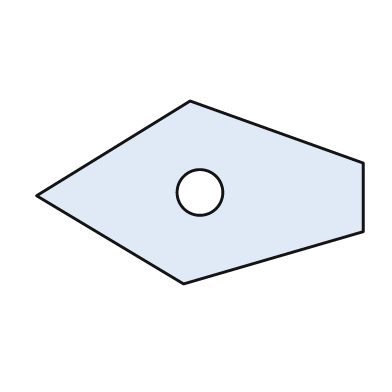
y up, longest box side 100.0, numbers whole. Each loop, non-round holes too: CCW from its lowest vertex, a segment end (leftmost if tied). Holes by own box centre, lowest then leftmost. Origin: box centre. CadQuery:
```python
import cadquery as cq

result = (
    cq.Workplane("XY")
    .moveTo(-5.0, -28.0)
    .lineTo(50.0, -12.0)
    .lineTo(50.0, 9.0)
    .lineTo(-3.0, 28.0)
    .lineTo(-50.0, -1.0)
    .close()
    .moveTo(0.0, 0.0)
    .circle(7.0)
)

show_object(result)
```